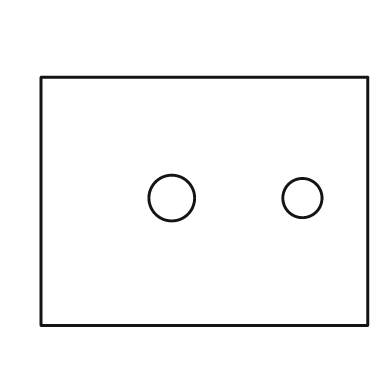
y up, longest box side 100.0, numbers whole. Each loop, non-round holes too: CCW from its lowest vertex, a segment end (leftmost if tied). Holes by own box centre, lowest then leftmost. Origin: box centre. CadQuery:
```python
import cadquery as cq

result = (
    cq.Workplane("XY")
    .moveTo(-50.0, -38.0)
    .lineTo(50.0, -38.0)
    .lineTo(50.0, 38.0)
    .lineTo(-50.0, 38.0)
    .close()
    .moveTo(-10.0, 1.0)
    .circle(7.0)
    .moveTo(30.0, 1.0)
    .circle(6.0)
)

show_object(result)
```